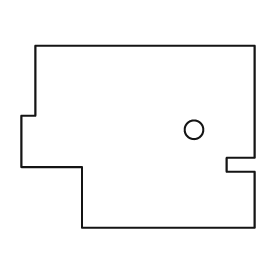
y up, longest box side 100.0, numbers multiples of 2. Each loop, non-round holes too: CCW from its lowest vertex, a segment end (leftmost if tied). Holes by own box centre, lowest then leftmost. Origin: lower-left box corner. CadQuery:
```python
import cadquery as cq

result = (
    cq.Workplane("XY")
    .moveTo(26.0, 0.0)
    .lineTo(100.0, 0.0)
    .lineTo(100.0, 24.0)
    .lineTo(88.0, 24.0)
    .lineTo(88.0, 30.0)
    .lineTo(100.0, 30.0)
    .lineTo(100.0, 78.0)
    .lineTo(6.0, 78.0)
    .lineTo(6.0, 48.0)
    .lineTo(0.0, 48.0)
    .lineTo(0.0, 26.0)
    .lineTo(26.0, 26.0)
    .close()
    .moveTo(74.0, 42.0)
    .circle(4.0)
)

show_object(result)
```